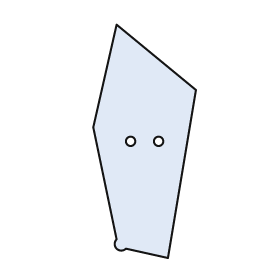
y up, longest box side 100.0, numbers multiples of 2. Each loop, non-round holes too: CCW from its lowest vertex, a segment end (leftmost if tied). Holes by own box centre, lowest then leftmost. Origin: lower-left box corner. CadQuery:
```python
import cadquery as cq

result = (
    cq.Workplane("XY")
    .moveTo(32.0, 0.0)
    .lineTo(44.0, 72.0)
    .lineTo(10.0, 100.0)
    .lineTo(0.0, 56.0)
    .lineTo(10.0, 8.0)
    .threePointArc((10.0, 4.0), (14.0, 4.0))
    .close()
    .moveTo(16.0, 50.0)
    .circle(2.0)
    .moveTo(28.0, 50.0)
    .circle(2.0)
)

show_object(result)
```